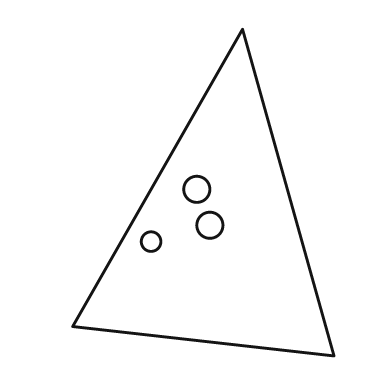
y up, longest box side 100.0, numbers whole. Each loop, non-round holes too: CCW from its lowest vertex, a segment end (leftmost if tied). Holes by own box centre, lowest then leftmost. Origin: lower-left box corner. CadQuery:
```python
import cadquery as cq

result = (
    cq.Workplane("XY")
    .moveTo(80.0, 0.0)
    .lineTo(52.0, 100.0)
    .lineTo(0.0, 9.0)
    .close()
    .moveTo(24.0, 35.0)
    .circle(3.0)
    .moveTo(42.0, 40.0)
    .circle(4.0)
    .moveTo(38.0, 51.0)
    .circle(4.0)
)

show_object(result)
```